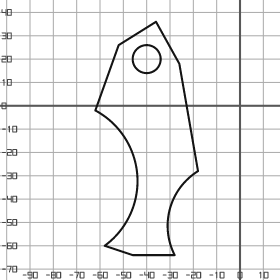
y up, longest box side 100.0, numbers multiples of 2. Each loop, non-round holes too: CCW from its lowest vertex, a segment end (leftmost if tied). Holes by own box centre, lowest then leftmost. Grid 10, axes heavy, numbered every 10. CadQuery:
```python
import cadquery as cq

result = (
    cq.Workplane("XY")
    .moveTo(-46.0, -64.0)
    .lineTo(-28.0, -64.0)
    .threePointArc((-30.0, -44.0), (-18.0, -28.0))
    .lineTo(-26.0, 18.0)
    .lineTo(-36.0, 36.0)
    .lineTo(-52.0, 26.0)
    .lineTo(-62.0, -2.0)
    .threePointArc((-44.0, -30.0), (-58.0, -60.0))
    .close()
    .moveTo(-40.0, 20.0)
    .circle(6.0)
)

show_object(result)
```